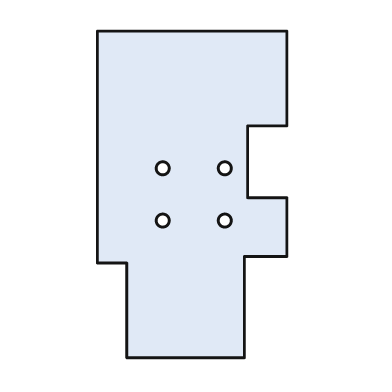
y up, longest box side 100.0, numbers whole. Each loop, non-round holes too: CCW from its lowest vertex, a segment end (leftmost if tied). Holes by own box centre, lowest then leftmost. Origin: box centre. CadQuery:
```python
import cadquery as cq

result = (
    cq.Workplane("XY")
    .moveTo(-20.0, -50.0)
    .lineTo(16.0, -50.0)
    .lineTo(16.0, -19.0)
    .lineTo(29.0, -19.0)
    .lineTo(29.0, -1.0)
    .lineTo(17.0, -1.0)
    .lineTo(17.0, 21.0)
    .lineTo(29.0, 21.0)
    .lineTo(29.0, 50.0)
    .lineTo(-29.0, 50.0)
    .lineTo(-29.0, -21.0)
    .lineTo(-20.0, -21.0)
    .close()
    .moveTo(-9.0, -8.0)
    .circle(2.0)
    .moveTo(10.0, -8.0)
    .circle(2.0)
    .moveTo(-9.0, 8.0)
    .circle(2.0)
    .moveTo(10.0, 8.0)
    .circle(2.0)
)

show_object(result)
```